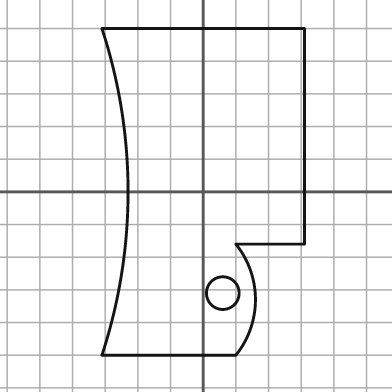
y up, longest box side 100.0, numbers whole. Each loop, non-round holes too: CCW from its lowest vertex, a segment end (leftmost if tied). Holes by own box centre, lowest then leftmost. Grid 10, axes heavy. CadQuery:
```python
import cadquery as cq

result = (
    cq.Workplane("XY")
    .moveTo(-31.0, -50.0)
    .lineTo(10.0, -50.0)
    .threePointArc((16.0, -33.0), (10.0, -16.0))
    .lineTo(31.0, -16.0)
    .lineTo(31.0, 50.0)
    .lineTo(-31.0, 50.0)
    .threePointArc((-23.0, 0.0), (-31.0, -50.0))
    .close()
    .moveTo(6.0, -31.0)
    .circle(5.0)
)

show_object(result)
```